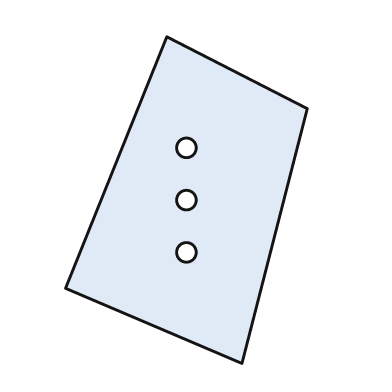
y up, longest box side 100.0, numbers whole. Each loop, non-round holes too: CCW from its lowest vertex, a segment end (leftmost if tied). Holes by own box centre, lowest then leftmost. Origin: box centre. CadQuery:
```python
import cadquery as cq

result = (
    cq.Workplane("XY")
    .moveTo(17.0, -50.0)
    .lineTo(37.0, 28.0)
    .lineTo(-6.0, 50.0)
    .lineTo(-37.0, -27.0)
    .close()
    .moveTo(0.0, -16.0)
    .circle(3.0)
    .moveTo(0.0, 0.0)
    .circle(3.0)
    .moveTo(0.0, 16.0)
    .circle(3.0)
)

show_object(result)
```